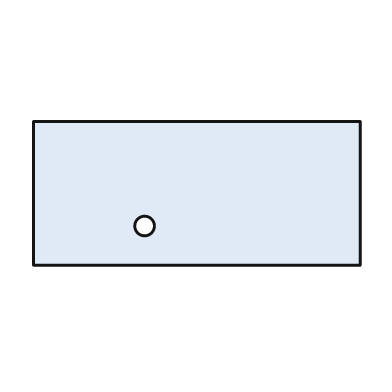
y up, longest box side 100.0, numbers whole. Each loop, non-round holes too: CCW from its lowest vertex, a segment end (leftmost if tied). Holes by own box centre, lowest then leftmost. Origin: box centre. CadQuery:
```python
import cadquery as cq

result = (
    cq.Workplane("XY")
    .moveTo(-50.0, -22.0)
    .lineTo(50.0, -22.0)
    .lineTo(50.0, 22.0)
    .lineTo(-50.0, 22.0)
    .close()
    .moveTo(-16.0, -10.0)
    .circle(3.0)
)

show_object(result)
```